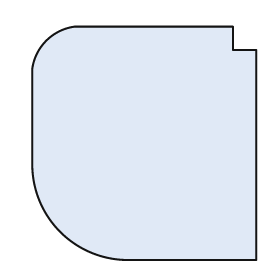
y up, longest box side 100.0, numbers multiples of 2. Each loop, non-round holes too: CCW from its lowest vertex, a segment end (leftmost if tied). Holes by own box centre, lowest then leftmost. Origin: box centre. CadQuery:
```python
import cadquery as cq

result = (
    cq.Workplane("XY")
    .moveTo(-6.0, -50.0)
    .lineTo(48.0, -50.0)
    .lineTo(48.0, 40.0)
    .lineTo(38.0, 40.0)
    .lineTo(38.0, 50.0)
    .lineTo(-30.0, 50.0)
    .threePointArc((-42.0, 44.0), (-48.0, 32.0))
    .lineTo(-48.0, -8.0)
    .threePointArc((-36.0, -38.0), (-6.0, -50.0))
    .close()
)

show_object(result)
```